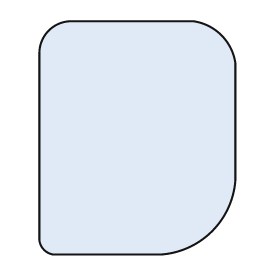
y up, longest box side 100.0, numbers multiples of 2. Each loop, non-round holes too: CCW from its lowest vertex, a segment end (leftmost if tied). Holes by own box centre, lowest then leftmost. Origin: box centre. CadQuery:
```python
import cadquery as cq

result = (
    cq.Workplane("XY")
    .moveTo(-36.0, -50.0)
    .lineTo(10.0, -50.0)
    .threePointArc((32.0, -40.0), (42.0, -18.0))
    .lineTo(42.0, 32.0)
    .threePointArc((36.0, 44.0), (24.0, 50.0))
    .lineTo(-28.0, 50.0)
    .threePointArc((-38.0, 46.0), (-42.0, 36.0))
    .lineTo(-42.0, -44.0)
    .threePointArc((-40.0, -48.0), (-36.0, -50.0))
    .close()
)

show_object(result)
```